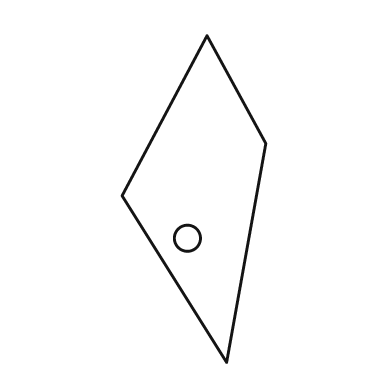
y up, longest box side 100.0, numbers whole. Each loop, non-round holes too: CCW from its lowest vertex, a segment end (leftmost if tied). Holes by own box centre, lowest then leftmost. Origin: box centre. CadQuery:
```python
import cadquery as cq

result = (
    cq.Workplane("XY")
    .moveTo(10.0, -50.0)
    .lineTo(22.0, 17.0)
    .lineTo(4.0, 50.0)
    .lineTo(-22.0, 1.0)
    .close()
    .moveTo(-2.0, -12.0)
    .circle(4.0)
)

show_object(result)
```